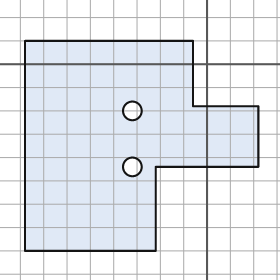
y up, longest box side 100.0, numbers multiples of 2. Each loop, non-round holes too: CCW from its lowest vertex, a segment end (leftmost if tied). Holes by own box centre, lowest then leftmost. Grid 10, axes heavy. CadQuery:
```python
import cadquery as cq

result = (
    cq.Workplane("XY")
    .moveTo(-78.0, -80.0)
    .lineTo(-22.0, -80.0)
    .lineTo(-22.0, -44.0)
    .lineTo(22.0, -44.0)
    .lineTo(22.0, -18.0)
    .lineTo(-6.0, -18.0)
    .lineTo(-6.0, 10.0)
    .lineTo(-78.0, 10.0)
    .close()
    .moveTo(-32.0, -44.0)
    .circle(4.0)
    .moveTo(-32.0, -20.0)
    .circle(4.0)
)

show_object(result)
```